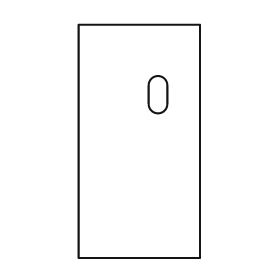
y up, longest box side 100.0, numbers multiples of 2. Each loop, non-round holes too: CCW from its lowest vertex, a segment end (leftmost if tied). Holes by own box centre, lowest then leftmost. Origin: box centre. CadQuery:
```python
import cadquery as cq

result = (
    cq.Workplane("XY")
    .moveTo(-26.0, -50.0)
    .lineTo(26.0, -50.0)
    .lineTo(26.0, 50.0)
    .lineTo(-26.0, 50.0)
    .close()
    .moveTo(4.0, 16.0)
    .threePointArc((8.0, 12.0), (12.0, 16.0))
    .lineTo(12.0, 24.0)
    .threePointArc((8.0, 28.0), (4.0, 24.0))
    .close()
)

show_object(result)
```